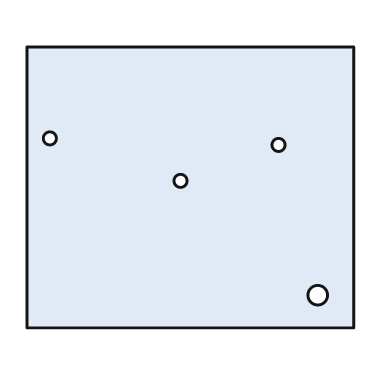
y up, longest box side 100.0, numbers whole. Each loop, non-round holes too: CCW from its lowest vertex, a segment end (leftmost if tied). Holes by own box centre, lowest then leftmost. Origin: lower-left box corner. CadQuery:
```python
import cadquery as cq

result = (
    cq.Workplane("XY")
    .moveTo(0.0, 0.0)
    .lineTo(100.0, 0.0)
    .lineTo(100.0, 86.0)
    .lineTo(0.0, 86.0)
    .close()
    .moveTo(89.0, 10.0)
    .circle(3.0)
    .moveTo(47.0, 45.0)
    .circle(2.0)
    .moveTo(77.0, 56.0)
    .circle(2.0)
    .moveTo(7.0, 58.0)
    .circle(2.0)
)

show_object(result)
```